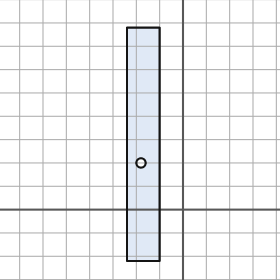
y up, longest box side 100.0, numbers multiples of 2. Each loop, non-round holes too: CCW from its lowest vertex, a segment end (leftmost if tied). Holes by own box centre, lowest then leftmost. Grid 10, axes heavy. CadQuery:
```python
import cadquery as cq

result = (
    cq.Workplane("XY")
    .moveTo(-24.0, -22.0)
    .lineTo(-10.0, -22.0)
    .lineTo(-10.0, 78.0)
    .lineTo(-24.0, 78.0)
    .close()
    .moveTo(-18.0, 20.0)
    .circle(2.0)
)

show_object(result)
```